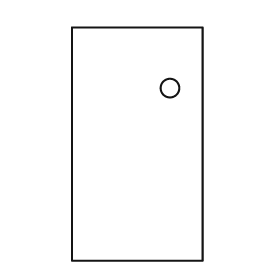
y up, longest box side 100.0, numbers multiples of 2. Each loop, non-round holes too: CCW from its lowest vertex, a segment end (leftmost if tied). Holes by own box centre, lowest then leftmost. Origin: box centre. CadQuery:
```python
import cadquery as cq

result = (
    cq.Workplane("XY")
    .moveTo(-28.0, -50.0)
    .lineTo(28.0, -50.0)
    .lineTo(28.0, 50.0)
    .lineTo(-28.0, 50.0)
    .close()
    .moveTo(14.0, 24.0)
    .circle(4.0)
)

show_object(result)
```